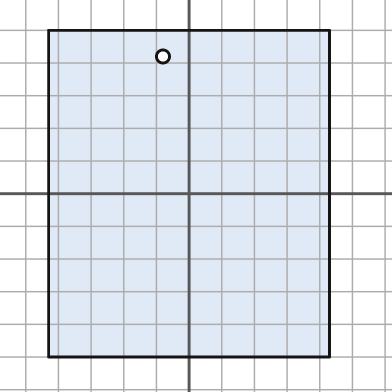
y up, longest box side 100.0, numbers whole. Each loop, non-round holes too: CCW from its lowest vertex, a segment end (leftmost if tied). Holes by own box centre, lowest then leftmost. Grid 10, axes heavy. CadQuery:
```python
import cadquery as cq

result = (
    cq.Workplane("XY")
    .moveTo(-43.0, -50.0)
    .lineTo(43.0, -50.0)
    .lineTo(43.0, 50.0)
    .lineTo(-43.0, 50.0)
    .close()
    .moveTo(-8.0, 42.0)
    .circle(2.0)
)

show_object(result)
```